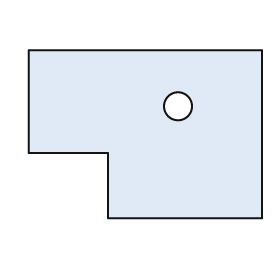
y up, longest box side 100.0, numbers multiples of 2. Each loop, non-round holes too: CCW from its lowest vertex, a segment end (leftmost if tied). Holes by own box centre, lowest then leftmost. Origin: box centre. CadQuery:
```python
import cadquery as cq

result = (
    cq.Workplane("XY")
    .moveTo(-16.0, -36.0)
    .lineTo(50.0, -36.0)
    .lineTo(50.0, 36.0)
    .lineTo(-50.0, 36.0)
    .lineTo(-50.0, -8.0)
    .lineTo(-16.0, -8.0)
    .close()
    .moveTo(14.0, 12.0)
    .circle(6.0)
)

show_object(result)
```